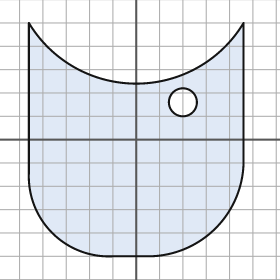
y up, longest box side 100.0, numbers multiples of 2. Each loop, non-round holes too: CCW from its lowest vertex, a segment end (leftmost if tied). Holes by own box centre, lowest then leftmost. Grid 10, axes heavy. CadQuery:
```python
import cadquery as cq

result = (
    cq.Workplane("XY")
    .moveTo(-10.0, -50.0)
    .lineTo(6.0, -50.0)
    .threePointArc((34.0, -38.0), (46.0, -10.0))
    .lineTo(46.0, 50.0)
    .threePointArc((0.0, 24.0), (-46.0, 50.0))
    .lineTo(-46.0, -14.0)
    .threePointArc((-36.0, -40.0), (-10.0, -50.0))
    .close()
    .moveTo(20.0, 16.0)
    .circle(6.0)
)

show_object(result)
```